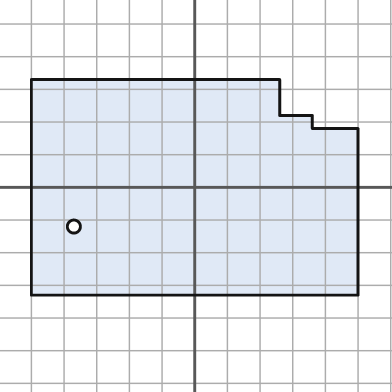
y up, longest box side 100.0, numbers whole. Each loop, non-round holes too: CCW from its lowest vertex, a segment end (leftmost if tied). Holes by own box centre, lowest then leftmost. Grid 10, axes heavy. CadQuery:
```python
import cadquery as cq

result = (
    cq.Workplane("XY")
    .moveTo(-50.0, -33.0)
    .lineTo(50.0, -33.0)
    .lineTo(50.0, 18.0)
    .lineTo(36.0, 18.0)
    .lineTo(36.0, 22.0)
    .lineTo(26.0, 22.0)
    .lineTo(26.0, 33.0)
    .lineTo(-50.0, 33.0)
    .close()
    .moveTo(-37.0, -12.0)
    .circle(2.0)
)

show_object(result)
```